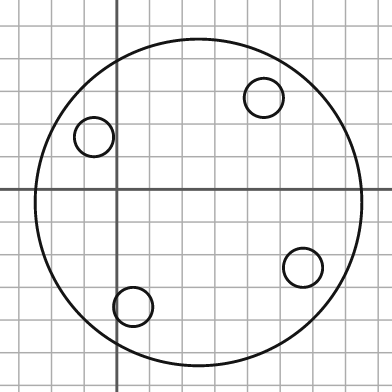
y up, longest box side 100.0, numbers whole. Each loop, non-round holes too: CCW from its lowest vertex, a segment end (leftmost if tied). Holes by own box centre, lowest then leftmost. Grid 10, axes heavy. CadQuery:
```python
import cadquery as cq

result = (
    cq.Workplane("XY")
    .moveTo(25.0, -4.0)
    .circle(50.0)
    .moveTo(5.0, -36.0)
    .circle(6.0)
    .moveTo(57.0, -24.0)
    .circle(6.0)
    .moveTo(-7.0, 16.0)
    .circle(6.0)
    .moveTo(45.0, 28.0)
    .circle(6.0)
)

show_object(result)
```